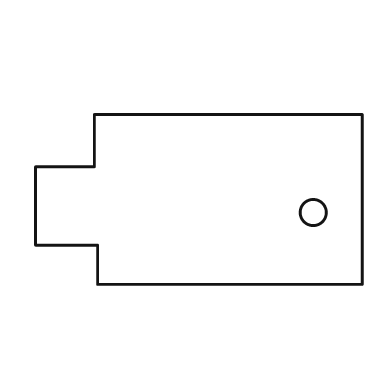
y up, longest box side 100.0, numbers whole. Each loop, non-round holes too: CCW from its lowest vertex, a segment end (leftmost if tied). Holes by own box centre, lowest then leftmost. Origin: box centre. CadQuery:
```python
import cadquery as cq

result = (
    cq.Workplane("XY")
    .moveTo(-31.0, -26.0)
    .lineTo(50.0, -26.0)
    .lineTo(50.0, 26.0)
    .lineTo(-32.0, 26.0)
    .lineTo(-32.0, 10.0)
    .lineTo(-50.0, 10.0)
    .lineTo(-50.0, -14.0)
    .lineTo(-31.0, -14.0)
    .close()
    .moveTo(35.0, -4.0)
    .circle(4.0)
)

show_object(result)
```